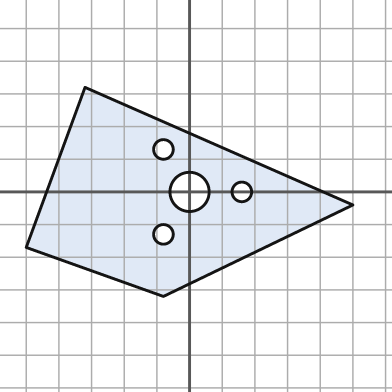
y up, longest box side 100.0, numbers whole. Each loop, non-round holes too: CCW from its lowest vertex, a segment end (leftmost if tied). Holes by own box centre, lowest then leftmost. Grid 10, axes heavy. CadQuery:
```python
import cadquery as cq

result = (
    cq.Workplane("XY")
    .moveTo(-8.0, -32.0)
    .lineTo(50.0, -4.0)
    .lineTo(-32.0, 32.0)
    .lineTo(-50.0, -17.0)
    .close()
    .moveTo(-8.0, -13.0)
    .circle(3.0)
    .moveTo(0.0, 0.0)
    .circle(6.0)
    .moveTo(16.0, 0.0)
    .circle(3.0)
    .moveTo(-8.0, 13.0)
    .circle(3.0)
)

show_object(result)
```